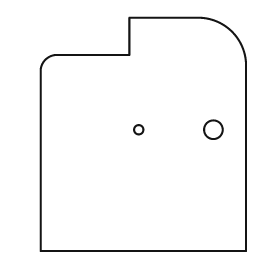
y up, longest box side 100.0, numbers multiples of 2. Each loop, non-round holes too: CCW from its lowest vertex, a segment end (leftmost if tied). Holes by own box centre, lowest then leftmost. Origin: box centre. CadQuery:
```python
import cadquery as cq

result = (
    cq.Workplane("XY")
    .moveTo(-44.0, -50.0)
    .lineTo(44.0, -50.0)
    .lineTo(44.0, 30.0)
    .threePointArc((38.0, 44.0), (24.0, 50.0))
    .lineTo(-6.0, 50.0)
    .lineTo(-6.0, 34.0)
    .lineTo(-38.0, 34.0)
    .threePointArc((-42.0, 32.0), (-44.0, 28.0))
    .close()
    .moveTo(-2.0, 2.0)
    .circle(2.0)
    .moveTo(30.0, 2.0)
    .circle(4.0)
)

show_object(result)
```